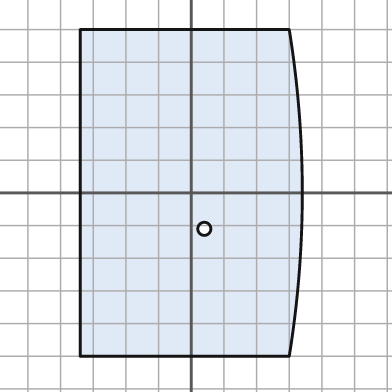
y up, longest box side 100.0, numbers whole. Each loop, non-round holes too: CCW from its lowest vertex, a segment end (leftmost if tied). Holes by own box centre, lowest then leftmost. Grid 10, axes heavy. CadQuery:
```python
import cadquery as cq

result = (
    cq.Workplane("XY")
    .moveTo(-34.0, -50.0)
    .lineTo(30.0, -50.0)
    .threePointArc((34.0, 0.0), (30.0, 50.0))
    .lineTo(-34.0, 50.0)
    .close()
    .moveTo(4.0, -11.0)
    .circle(2.0)
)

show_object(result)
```